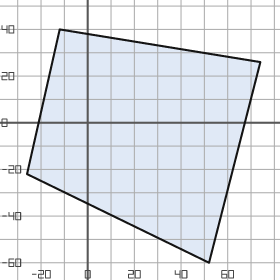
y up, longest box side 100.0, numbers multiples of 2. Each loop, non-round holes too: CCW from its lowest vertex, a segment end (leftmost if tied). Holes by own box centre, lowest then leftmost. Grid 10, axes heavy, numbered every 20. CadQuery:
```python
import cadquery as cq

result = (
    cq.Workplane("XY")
    .moveTo(52.0, -60.0)
    .lineTo(74.0, 26.0)
    .lineTo(-12.0, 40.0)
    .lineTo(-26.0, -22.0)
    .close()
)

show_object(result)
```